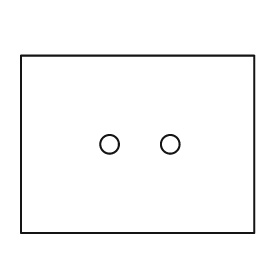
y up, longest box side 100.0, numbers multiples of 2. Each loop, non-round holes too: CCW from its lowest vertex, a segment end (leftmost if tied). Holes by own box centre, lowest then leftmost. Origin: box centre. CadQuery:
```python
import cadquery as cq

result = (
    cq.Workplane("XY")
    .moveTo(-50.0, -38.0)
    .lineTo(50.0, -38.0)
    .lineTo(50.0, 38.0)
    .lineTo(-50.0, 38.0)
    .close()
    .moveTo(-12.0, 0.0)
    .circle(4.0)
    .moveTo(14.0, 0.0)
    .circle(4.0)
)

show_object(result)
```